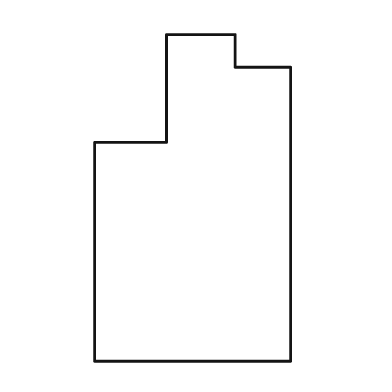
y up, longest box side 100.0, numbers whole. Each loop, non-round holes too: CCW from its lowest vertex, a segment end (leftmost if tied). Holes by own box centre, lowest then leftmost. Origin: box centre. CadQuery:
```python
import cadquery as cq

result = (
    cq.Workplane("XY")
    .moveTo(-30.0, -50.0)
    .lineTo(30.0, -50.0)
    .lineTo(30.0, 40.0)
    .lineTo(13.0, 40.0)
    .lineTo(13.0, 50.0)
    .lineTo(-8.0, 50.0)
    .lineTo(-8.0, 17.0)
    .lineTo(-30.0, 17.0)
    .close()
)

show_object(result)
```